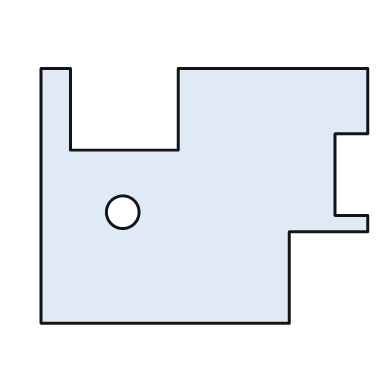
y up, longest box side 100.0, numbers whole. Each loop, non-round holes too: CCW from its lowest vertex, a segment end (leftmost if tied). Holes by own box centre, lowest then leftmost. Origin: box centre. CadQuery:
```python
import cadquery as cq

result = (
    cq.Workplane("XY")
    .moveTo(-50.0, -39.0)
    .lineTo(26.0, -39.0)
    .lineTo(26.0, -11.0)
    .lineTo(50.0, -11.0)
    .lineTo(50.0, -6.0)
    .lineTo(40.0, -6.0)
    .lineTo(40.0, 19.0)
    .lineTo(50.0, 19.0)
    .lineTo(50.0, 39.0)
    .lineTo(-8.0, 39.0)
    .lineTo(-8.0, 14.0)
    .lineTo(-41.0, 14.0)
    .lineTo(-41.0, 39.0)
    .lineTo(-50.0, 39.0)
    .close()
    .moveTo(-25.0, -5.0)
    .circle(5.0)
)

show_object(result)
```